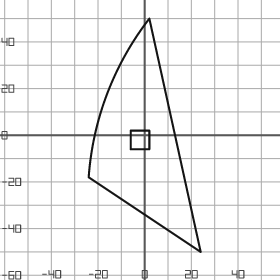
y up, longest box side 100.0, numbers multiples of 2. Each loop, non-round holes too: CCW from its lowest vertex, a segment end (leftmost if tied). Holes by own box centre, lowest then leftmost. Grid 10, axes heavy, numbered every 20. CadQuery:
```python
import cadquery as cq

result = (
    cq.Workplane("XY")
    .moveTo(24.0, -50.0)
    .lineTo(2.0, 50.0)
    .threePointArc((-16.0, 18.0), (-24.0, -18.0))
    .close()
    .moveTo(-6.0, -6.0)
    .lineTo(2.0, -6.0)
    .lineTo(2.0, 2.0)
    .lineTo(-6.0, 2.0)
    .close()
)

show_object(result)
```